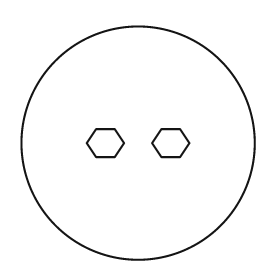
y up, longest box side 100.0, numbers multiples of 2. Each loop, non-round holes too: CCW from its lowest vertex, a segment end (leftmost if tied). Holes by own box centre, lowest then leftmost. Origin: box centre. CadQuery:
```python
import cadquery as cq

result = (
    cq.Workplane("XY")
    .moveTo(0.0, 0.0)
    .circle(50.0)
    .moveTo(-18.0, -6.0)
    .lineTo(-10.0, -6.0)
    .lineTo(-6.0, 0.0)
    .lineTo(-10.0, 6.0)
    .lineTo(-18.0, 6.0)
    .lineTo(-22.0, 0.0)
    .close()
    .moveTo(10.0, -6.0)
    .lineTo(18.0, -6.0)
    .lineTo(22.0, 0.0)
    .lineTo(18.0, 6.0)
    .lineTo(10.0, 6.0)
    .lineTo(6.0, 0.0)
    .close()
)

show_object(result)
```